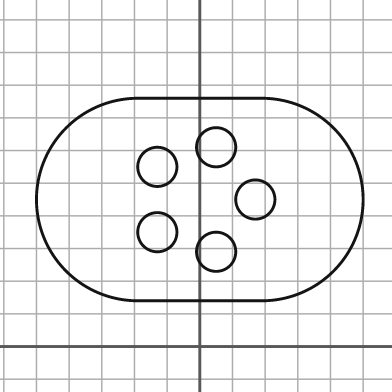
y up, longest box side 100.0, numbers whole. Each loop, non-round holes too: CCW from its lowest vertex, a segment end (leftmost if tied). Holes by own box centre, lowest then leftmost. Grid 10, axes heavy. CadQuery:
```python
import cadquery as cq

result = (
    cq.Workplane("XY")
    .moveTo(-19.0, 14.0)
    .lineTo(19.0, 14.0)
    .threePointArc((50.0, 45.0), (19.0, 76.0))
    .lineTo(-19.0, 76.0)
    .threePointArc((-50.0, 45.0), (-19.0, 14.0))
    .close()
    .moveTo(5.0, 29.0)
    .circle(6.0)
    .moveTo(-13.0, 35.0)
    .circle(6.0)
    .moveTo(17.0, 45.0)
    .circle(6.0)
    .moveTo(-13.0, 55.0)
    .circle(6.0)
    .moveTo(5.0, 61.0)
    .circle(6.0)
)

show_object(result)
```